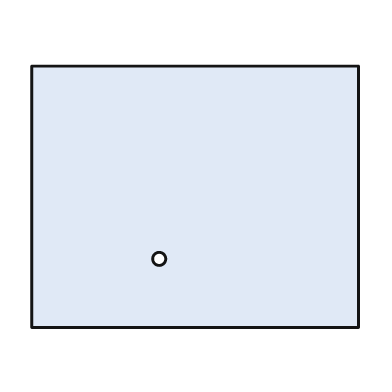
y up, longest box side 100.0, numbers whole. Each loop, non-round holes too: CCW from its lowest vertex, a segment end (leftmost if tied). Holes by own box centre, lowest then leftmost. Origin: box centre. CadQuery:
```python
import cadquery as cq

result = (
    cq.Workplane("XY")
    .moveTo(-50.0, -40.0)
    .lineTo(50.0, -40.0)
    .lineTo(50.0, 40.0)
    .lineTo(-50.0, 40.0)
    .close()
    .moveTo(-11.0, -19.0)
    .circle(2.0)
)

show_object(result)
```